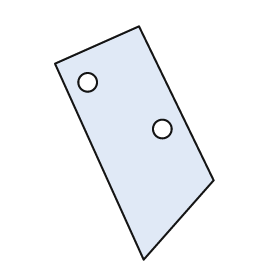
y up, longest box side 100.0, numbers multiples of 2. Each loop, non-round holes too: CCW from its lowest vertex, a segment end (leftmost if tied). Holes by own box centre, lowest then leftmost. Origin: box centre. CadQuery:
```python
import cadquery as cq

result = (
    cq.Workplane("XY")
    .moveTo(4.0, -50.0)
    .lineTo(34.0, -16.0)
    .lineTo(2.0, 50.0)
    .lineTo(-34.0, 34.0)
    .close()
    .moveTo(12.0, 6.0)
    .circle(4.0)
    .moveTo(-20.0, 26.0)
    .circle(4.0)
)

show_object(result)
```